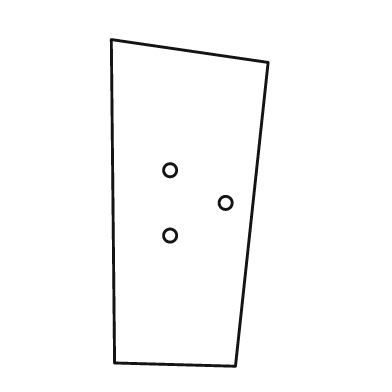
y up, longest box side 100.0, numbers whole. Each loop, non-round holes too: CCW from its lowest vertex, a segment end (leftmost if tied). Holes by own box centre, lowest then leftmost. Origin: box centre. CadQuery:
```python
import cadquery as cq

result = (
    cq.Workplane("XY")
    .moveTo(14.0, -50.0)
    .lineTo(24.0, 43.0)
    .lineTo(-24.0, 50.0)
    .lineTo(-23.0, -49.0)
    .close()
    .moveTo(-6.0, -10.0)
    .circle(2.0)
    .moveTo(11.0, 0.0)
    .circle(2.0)
    .moveTo(-6.0, 10.0)
    .circle(2.0)
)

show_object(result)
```